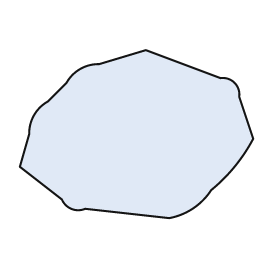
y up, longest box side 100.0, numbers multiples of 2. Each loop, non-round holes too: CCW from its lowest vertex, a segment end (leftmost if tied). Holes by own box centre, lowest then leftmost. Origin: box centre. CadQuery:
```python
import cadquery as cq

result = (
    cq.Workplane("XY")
    .moveTo(14.0, -36.0)
    .threePointArc((24.0, -32.0), (32.0, -24.0))
    .threePointArc((42.0, -14.0), (50.0, -2.0))
    .lineTo(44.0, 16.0)
    .threePointArc((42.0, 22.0), (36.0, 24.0))
    .lineTo(4.0, 36.0)
    .lineTo(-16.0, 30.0)
    .threePointArc((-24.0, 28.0), (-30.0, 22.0))
    .lineTo(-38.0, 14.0)
    .threePointArc((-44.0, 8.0), (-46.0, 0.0))
    .lineTo(-50.0, -14.0)
    .lineTo(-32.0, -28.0)
    .threePointArc((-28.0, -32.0), (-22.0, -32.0))
    .close()
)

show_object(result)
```